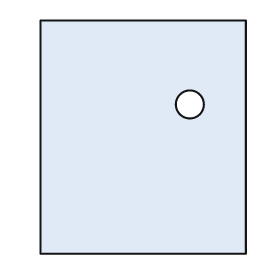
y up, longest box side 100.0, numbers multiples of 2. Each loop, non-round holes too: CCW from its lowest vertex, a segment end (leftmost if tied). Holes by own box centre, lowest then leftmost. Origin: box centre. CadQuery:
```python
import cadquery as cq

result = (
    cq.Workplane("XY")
    .moveTo(-44.0, -50.0)
    .lineTo(44.0, -50.0)
    .lineTo(44.0, 50.0)
    .lineTo(-44.0, 50.0)
    .close()
    .moveTo(20.0, 14.0)
    .circle(6.0)
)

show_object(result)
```